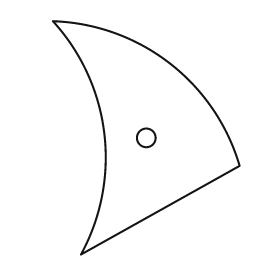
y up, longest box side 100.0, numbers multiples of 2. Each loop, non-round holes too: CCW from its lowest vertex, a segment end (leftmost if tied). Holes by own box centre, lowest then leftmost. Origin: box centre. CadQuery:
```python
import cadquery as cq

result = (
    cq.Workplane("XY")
    .moveTo(-28.0, -50.0)
    .lineTo(40.0, -12.0)
    .threePointArc((10.0, 32.0), (-40.0, 50.0))
    .threePointArc((-18.0, 2.0), (-28.0, -50.0))
    .close()
    .moveTo(0.0, 0.0)
    .circle(4.0)
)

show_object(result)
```